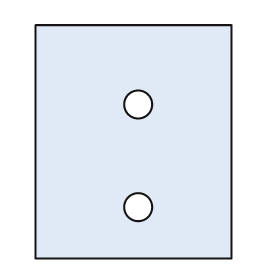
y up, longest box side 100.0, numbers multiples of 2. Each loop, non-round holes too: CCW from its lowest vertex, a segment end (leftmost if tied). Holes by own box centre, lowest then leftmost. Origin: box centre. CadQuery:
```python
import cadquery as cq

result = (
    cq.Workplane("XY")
    .moveTo(-42.0, -50.0)
    .lineTo(42.0, -50.0)
    .lineTo(42.0, 50.0)
    .lineTo(-42.0, 50.0)
    .close()
    .moveTo(2.0, -28.0)
    .circle(6.0)
    .moveTo(2.0, 16.0)
    .circle(6.0)
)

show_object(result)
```